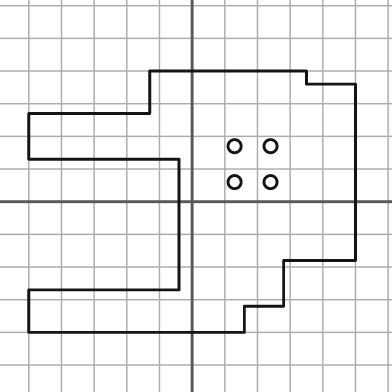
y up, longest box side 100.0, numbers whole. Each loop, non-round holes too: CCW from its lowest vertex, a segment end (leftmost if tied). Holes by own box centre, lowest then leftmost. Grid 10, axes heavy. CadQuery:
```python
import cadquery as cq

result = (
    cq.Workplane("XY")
    .moveTo(-50.0, -40.0)
    .lineTo(16.0, -40.0)
    .lineTo(16.0, -32.0)
    .lineTo(28.0, -32.0)
    .lineTo(28.0, -18.0)
    .lineTo(50.0, -18.0)
    .lineTo(50.0, 36.0)
    .lineTo(35.0, 36.0)
    .lineTo(35.0, 40.0)
    .lineTo(-13.0, 40.0)
    .lineTo(-13.0, 27.0)
    .lineTo(-50.0, 27.0)
    .lineTo(-50.0, 13.0)
    .lineTo(-4.0, 13.0)
    .lineTo(-4.0, -27.0)
    .lineTo(-50.0, -27.0)
    .close()
    .moveTo(13.0, 6.0)
    .circle(2.0)
    .moveTo(24.0, 6.0)
    .circle(2.0)
    .moveTo(13.0, 17.0)
    .circle(2.0)
    .moveTo(24.0, 17.0)
    .circle(2.0)
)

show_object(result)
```